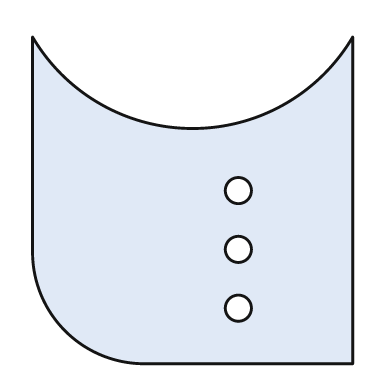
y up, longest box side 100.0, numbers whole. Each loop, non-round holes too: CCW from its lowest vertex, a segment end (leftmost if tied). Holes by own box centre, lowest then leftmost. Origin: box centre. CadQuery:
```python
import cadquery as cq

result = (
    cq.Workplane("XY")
    .moveTo(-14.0, -50.0)
    .lineTo(49.0, -50.0)
    .lineTo(49.0, 50.0)
    .threePointArc((0.0, 22.0), (-49.0, 50.0))
    .lineTo(-49.0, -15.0)
    .threePointArc((-39.0, -40.0), (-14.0, -50.0))
    .close()
    .moveTo(14.0, -33.0)
    .circle(4.0)
    .moveTo(14.0, -15.0)
    .circle(4.0)
    .moveTo(14.0, 3.0)
    .circle(4.0)
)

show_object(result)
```